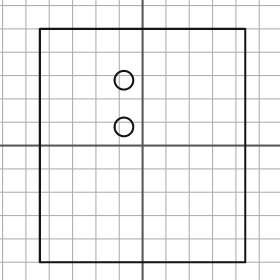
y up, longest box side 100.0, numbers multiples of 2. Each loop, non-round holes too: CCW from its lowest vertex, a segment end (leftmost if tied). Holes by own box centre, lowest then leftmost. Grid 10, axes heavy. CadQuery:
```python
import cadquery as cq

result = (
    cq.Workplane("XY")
    .moveTo(-44.0, -50.0)
    .lineTo(44.0, -50.0)
    .lineTo(44.0, 50.0)
    .lineTo(-44.0, 50.0)
    .close()
    .moveTo(-8.0, 8.0)
    .circle(4.0)
    .moveTo(-8.0, 28.0)
    .circle(4.0)
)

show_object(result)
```